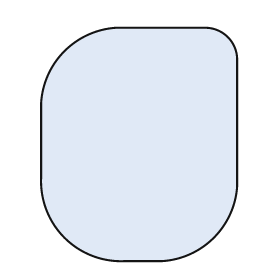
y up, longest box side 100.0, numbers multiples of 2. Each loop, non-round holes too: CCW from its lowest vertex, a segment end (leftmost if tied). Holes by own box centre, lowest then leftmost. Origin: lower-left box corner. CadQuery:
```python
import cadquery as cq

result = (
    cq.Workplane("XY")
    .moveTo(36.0, 0.0)
    .lineTo(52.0, 0.0)
    .threePointArc((74.0, 10.0), (84.0, 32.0))
    .lineTo(84.0, 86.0)
    .threePointArc((80.0, 96.0), (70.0, 100.0))
    .lineTo(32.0, 100.0)
    .threePointArc((10.0, 90.0), (0.0, 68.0))
    .lineTo(0.0, 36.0)
    .threePointArc((10.0, 10.0), (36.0, 0.0))
    .close()
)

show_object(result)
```